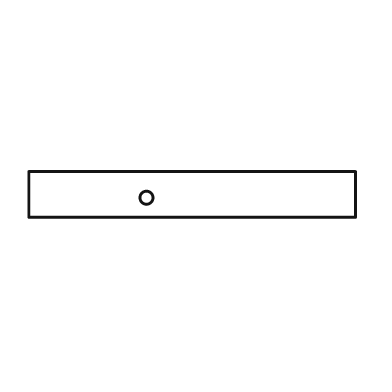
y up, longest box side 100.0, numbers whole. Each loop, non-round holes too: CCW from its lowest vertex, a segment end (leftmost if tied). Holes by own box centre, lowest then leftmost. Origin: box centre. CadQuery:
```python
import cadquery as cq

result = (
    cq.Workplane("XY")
    .moveTo(-50.0, -7.0)
    .lineTo(50.0, -7.0)
    .lineTo(50.0, 7.0)
    .lineTo(-50.0, 7.0)
    .close()
    .moveTo(-14.0, -1.0)
    .circle(2.0)
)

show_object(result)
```